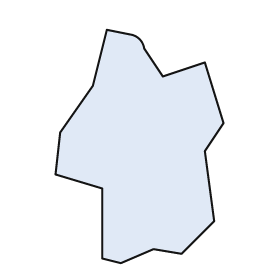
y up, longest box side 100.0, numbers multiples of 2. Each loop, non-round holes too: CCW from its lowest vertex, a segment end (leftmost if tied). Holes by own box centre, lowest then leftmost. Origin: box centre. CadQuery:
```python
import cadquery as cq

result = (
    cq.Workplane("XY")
    .moveTo(-8.0, -50.0)
    .lineTo(6.0, -44.0)
    .lineTo(18.0, -46.0)
    .lineTo(32.0, -32.0)
    .lineTo(28.0, -2.0)
    .lineTo(36.0, 10.0)
    .lineTo(28.0, 36.0)
    .lineTo(10.0, 30.0)
    .lineTo(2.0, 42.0)
    .threePointArc((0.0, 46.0), (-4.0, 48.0))
    .lineTo(-14.0, 50.0)
    .lineTo(-20.0, 26.0)
    .lineTo(-34.0, 6.0)
    .lineTo(-36.0, -12.0)
    .lineTo(-16.0, -18.0)
    .lineTo(-16.0, -48.0)
    .close()
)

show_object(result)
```